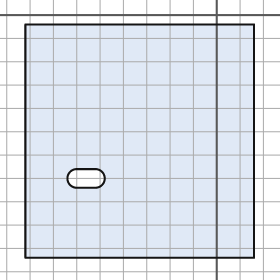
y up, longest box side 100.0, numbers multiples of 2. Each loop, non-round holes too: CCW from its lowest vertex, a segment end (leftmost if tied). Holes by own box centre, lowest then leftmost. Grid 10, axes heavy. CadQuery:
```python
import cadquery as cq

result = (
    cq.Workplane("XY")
    .moveTo(-82.0, -104.0)
    .lineTo(16.0, -104.0)
    .lineTo(16.0, -4.0)
    .lineTo(-82.0, -4.0)
    .close()
    .moveTo(-60.0, -74.0)
    .lineTo(-52.0, -74.0)
    .threePointArc((-48.0, -70.0), (-52.0, -66.0))
    .lineTo(-60.0, -66.0)
    .threePointArc((-64.0, -70.0), (-60.0, -74.0))
    .close()
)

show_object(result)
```